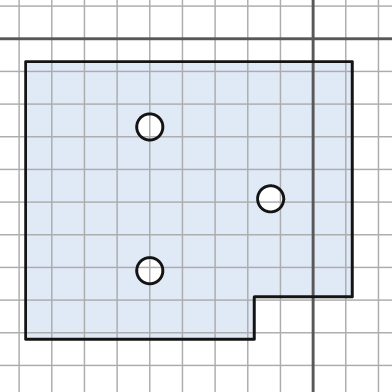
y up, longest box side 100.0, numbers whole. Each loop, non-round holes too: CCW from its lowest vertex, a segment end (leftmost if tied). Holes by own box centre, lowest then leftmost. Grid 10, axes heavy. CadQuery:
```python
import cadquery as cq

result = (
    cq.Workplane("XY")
    .moveTo(-88.0, -92.0)
    .lineTo(-18.0, -92.0)
    .lineTo(-18.0, -79.0)
    .lineTo(12.0, -79.0)
    .lineTo(12.0, -7.0)
    .lineTo(-88.0, -7.0)
    .close()
    .moveTo(-50.0, -71.0)
    .circle(4.0)
    .moveTo(-13.0, -49.0)
    .circle(4.0)
    .moveTo(-50.0, -27.0)
    .circle(4.0)
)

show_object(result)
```